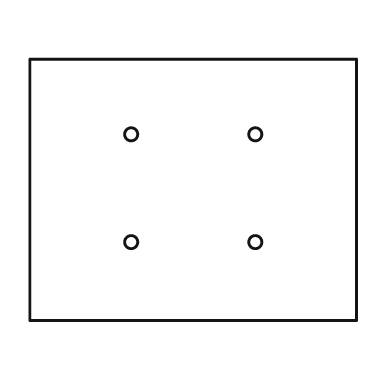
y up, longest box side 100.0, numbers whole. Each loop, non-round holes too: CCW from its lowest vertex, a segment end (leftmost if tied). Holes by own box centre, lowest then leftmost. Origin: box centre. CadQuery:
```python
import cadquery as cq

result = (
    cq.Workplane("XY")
    .moveTo(-50.0, -40.0)
    .lineTo(50.0, -40.0)
    .lineTo(50.0, 40.0)
    .lineTo(-50.0, 40.0)
    .close()
    .moveTo(-19.0, -16.0)
    .circle(2.0)
    .moveTo(19.0, -16.0)
    .circle(2.0)
    .moveTo(-19.0, 17.0)
    .circle(2.0)
    .moveTo(19.0, 17.0)
    .circle(2.0)
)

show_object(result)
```